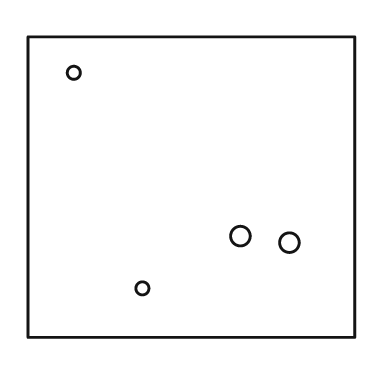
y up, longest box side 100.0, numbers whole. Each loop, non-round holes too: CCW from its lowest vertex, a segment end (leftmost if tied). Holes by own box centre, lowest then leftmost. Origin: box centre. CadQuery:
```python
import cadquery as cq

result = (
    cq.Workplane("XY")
    .moveTo(-50.0, -46.0)
    .lineTo(50.0, -46.0)
    .lineTo(50.0, 46.0)
    .lineTo(-50.0, 46.0)
    .close()
    .moveTo(-15.0, -31.0)
    .circle(2.0)
    .moveTo(30.0, -17.0)
    .circle(3.0)
    .moveTo(15.0, -15.0)
    .circle(3.0)
    .moveTo(-36.0, 35.0)
    .circle(2.0)
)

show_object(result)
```